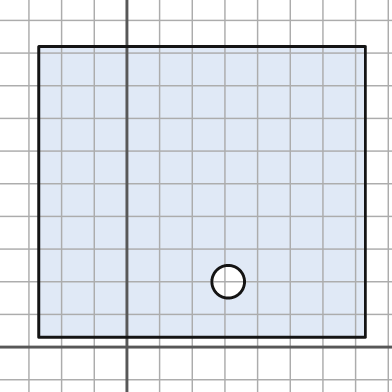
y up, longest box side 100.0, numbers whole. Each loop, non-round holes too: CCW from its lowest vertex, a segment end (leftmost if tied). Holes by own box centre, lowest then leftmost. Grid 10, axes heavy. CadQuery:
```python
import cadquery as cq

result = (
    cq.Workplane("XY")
    .moveTo(-27.0, 3.0)
    .lineTo(73.0, 3.0)
    .lineTo(73.0, 92.0)
    .lineTo(-27.0, 92.0)
    .close()
    .moveTo(31.0, 20.0)
    .circle(5.0)
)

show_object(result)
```